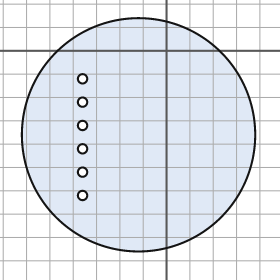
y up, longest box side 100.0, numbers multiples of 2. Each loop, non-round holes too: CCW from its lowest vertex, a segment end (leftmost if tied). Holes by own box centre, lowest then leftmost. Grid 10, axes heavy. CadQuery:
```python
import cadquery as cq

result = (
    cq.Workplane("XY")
    .moveTo(-12.0, -36.0)
    .circle(50.0)
    .moveTo(-36.0, -62.0)
    .circle(2.0)
    .moveTo(-36.0, -52.0)
    .circle(2.0)
    .moveTo(-36.0, -42.0)
    .circle(2.0)
    .moveTo(-36.0, -32.0)
    .circle(2.0)
    .moveTo(-36.0, -22.0)
    .circle(2.0)
    .moveTo(-36.0, -12.0)
    .circle(2.0)
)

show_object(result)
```